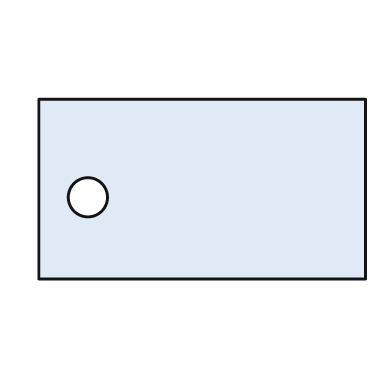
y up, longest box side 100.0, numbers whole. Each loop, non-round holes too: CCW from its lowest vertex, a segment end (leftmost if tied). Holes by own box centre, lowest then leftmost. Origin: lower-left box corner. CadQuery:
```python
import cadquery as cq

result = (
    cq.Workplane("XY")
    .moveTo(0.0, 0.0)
    .lineTo(100.0, 0.0)
    .lineTo(100.0, 55.0)
    .lineTo(0.0, 55.0)
    .close()
    .moveTo(15.0, 25.0)
    .circle(6.0)
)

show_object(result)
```